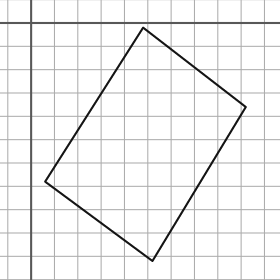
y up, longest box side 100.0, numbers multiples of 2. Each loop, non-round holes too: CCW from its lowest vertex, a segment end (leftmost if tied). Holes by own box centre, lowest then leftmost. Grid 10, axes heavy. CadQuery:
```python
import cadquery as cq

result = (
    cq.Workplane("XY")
    .moveTo(52.0, -102.0)
    .lineTo(92.0, -36.0)
    .lineTo(48.0, -2.0)
    .lineTo(6.0, -68.0)
    .close()
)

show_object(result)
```